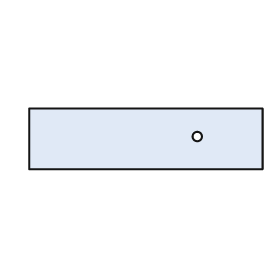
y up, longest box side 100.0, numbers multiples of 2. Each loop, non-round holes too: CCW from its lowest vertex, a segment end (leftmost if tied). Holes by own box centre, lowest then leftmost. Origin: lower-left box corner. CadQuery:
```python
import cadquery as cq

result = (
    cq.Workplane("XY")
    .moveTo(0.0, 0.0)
    .lineTo(100.0, 0.0)
    .lineTo(100.0, 26.0)
    .lineTo(0.0, 26.0)
    .close()
    .moveTo(72.0, 14.0)
    .circle(2.0)
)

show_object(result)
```